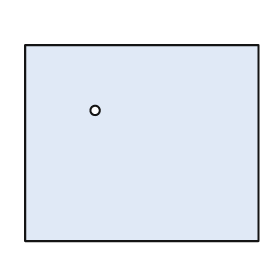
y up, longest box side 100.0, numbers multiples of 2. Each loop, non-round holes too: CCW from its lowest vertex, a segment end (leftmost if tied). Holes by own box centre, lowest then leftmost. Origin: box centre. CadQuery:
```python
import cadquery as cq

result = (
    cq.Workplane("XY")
    .moveTo(-50.0, -42.0)
    .lineTo(50.0, -42.0)
    .lineTo(50.0, 42.0)
    .lineTo(-50.0, 42.0)
    .close()
    .moveTo(-20.0, 14.0)
    .circle(2.0)
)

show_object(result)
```